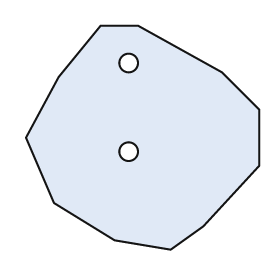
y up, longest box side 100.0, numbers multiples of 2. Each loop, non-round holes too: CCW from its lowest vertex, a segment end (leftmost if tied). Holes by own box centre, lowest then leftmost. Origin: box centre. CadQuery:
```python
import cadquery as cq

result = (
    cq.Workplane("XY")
    .moveTo(12.0, -48.0)
    .lineTo(26.0, -38.0)
    .lineTo(50.0, -12.0)
    .lineTo(50.0, 12.0)
    .lineTo(34.0, 28.0)
    .lineTo(-2.0, 48.0)
    .lineTo(-18.0, 48.0)
    .lineTo(-36.0, 26.0)
    .lineTo(-50.0, 0.0)
    .lineTo(-38.0, -28.0)
    .lineTo(-12.0, -44.0)
    .close()
    .moveTo(-6.0, -6.0)
    .circle(4.0)
    .moveTo(-6.0, 32.0)
    .circle(4.0)
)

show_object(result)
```